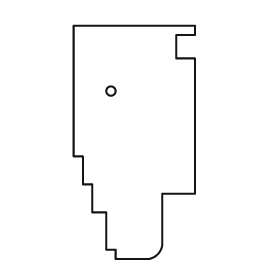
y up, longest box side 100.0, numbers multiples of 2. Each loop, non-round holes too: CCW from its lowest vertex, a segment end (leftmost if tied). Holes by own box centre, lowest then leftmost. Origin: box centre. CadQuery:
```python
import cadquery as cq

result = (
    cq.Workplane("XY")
    .moveTo(-8.0, -50.0)
    .lineTo(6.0, -50.0)
    .threePointArc((10.0, -48.0), (12.0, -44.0))
    .lineTo(12.0, -22.0)
    .lineTo(26.0, -22.0)
    .lineTo(26.0, 36.0)
    .lineTo(18.0, 36.0)
    .lineTo(18.0, 46.0)
    .lineTo(26.0, 46.0)
    .lineTo(26.0, 50.0)
    .lineTo(-26.0, 50.0)
    .lineTo(-26.0, -6.0)
    .lineTo(-22.0, -6.0)
    .lineTo(-22.0, -18.0)
    .lineTo(-18.0, -18.0)
    .lineTo(-18.0, -30.0)
    .lineTo(-12.0, -30.0)
    .lineTo(-12.0, -46.0)
    .lineTo(-8.0, -46.0)
    .close()
    .moveTo(-10.0, 22.0)
    .circle(2.0)
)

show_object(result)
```